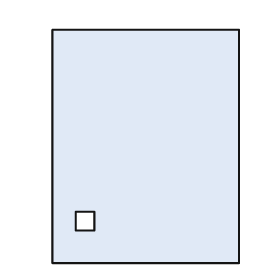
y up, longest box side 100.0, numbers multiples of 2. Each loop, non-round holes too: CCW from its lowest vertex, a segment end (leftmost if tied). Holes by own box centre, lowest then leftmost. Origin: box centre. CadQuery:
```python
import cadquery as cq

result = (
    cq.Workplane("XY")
    .moveTo(-40.0, -50.0)
    .lineTo(40.0, -50.0)
    .lineTo(40.0, 50.0)
    .lineTo(-40.0, 50.0)
    .close()
    .moveTo(-30.0, -36.0)
    .lineTo(-22.0, -36.0)
    .lineTo(-22.0, -28.0)
    .lineTo(-30.0, -28.0)
    .close()
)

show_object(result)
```